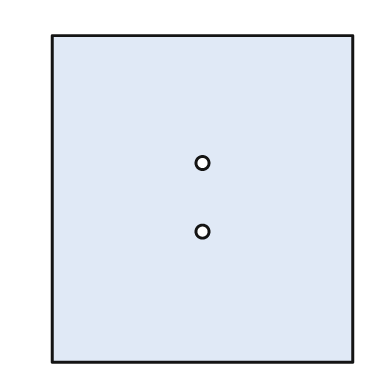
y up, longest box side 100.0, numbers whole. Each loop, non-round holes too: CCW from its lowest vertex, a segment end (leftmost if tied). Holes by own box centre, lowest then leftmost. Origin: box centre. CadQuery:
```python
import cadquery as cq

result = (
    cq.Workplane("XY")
    .moveTo(-46.0, -50.0)
    .lineTo(46.0, -50.0)
    .lineTo(46.0, 50.0)
    .lineTo(-46.0, 50.0)
    .close()
    .moveTo(0.0, -10.0)
    .circle(2.0)
    .moveTo(0.0, 11.0)
    .circle(2.0)
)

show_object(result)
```